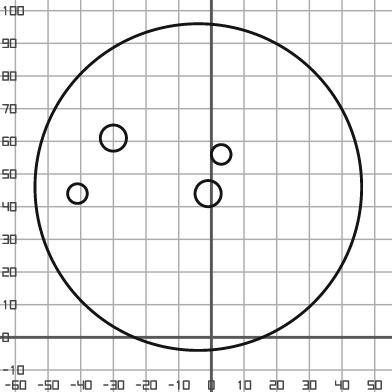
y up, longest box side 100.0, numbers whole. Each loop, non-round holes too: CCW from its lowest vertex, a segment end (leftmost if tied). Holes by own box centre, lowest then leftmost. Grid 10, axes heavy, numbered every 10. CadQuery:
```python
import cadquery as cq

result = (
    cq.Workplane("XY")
    .moveTo(-4.0, 46.0)
    .circle(50.0)
    .moveTo(-41.0, 44.0)
    .circle(3.0)
    .moveTo(-1.0, 44.0)
    .circle(4.0)
    .moveTo(3.0, 56.0)
    .circle(3.0)
    .moveTo(-30.0, 61.0)
    .circle(4.0)
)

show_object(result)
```